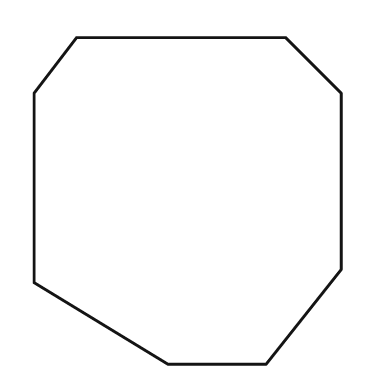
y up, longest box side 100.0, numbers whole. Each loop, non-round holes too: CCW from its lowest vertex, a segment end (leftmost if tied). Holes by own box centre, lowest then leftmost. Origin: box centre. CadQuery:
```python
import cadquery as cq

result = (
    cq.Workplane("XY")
    .moveTo(-6.0, -50.0)
    .lineTo(24.0, -50.0)
    .lineTo(47.0, -21.0)
    .lineTo(47.0, 33.0)
    .lineTo(30.0, 50.0)
    .lineTo(-34.0, 50.0)
    .lineTo(-47.0, 33.0)
    .lineTo(-47.0, -25.0)
    .close()
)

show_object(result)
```